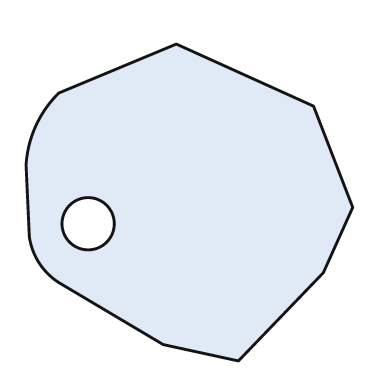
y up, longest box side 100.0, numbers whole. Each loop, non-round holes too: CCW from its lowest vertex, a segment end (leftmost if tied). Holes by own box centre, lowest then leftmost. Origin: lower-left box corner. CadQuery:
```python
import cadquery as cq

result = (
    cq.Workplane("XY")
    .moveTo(65.0, 0.0)
    .lineTo(91.0, 27.0)
    .lineTo(100.0, 47.0)
    .lineTo(88.0, 78.0)
    .lineTo(46.0, 97.0)
    .lineTo(10.0, 82.0)
    .threePointArc((3.0, 72.0), (0.0, 60.0))
    .lineTo(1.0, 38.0)
    .threePointArc((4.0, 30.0), (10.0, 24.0))
    .lineTo(42.0, 5.0)
    .close()
    .moveTo(19.0, 42.0)
    .circle(8.0)
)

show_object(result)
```